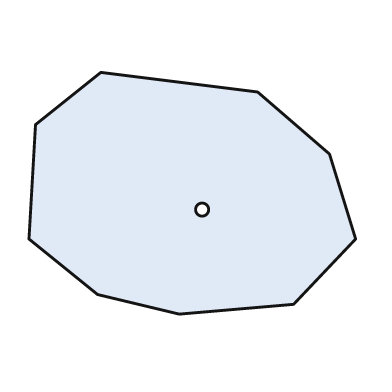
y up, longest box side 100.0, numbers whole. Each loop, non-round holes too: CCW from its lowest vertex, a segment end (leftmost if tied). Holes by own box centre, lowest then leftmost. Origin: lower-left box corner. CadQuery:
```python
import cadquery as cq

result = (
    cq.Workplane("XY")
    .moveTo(46.0, 0.0)
    .lineTo(81.0, 3.0)
    .lineTo(100.0, 23.0)
    .lineTo(92.0, 49.0)
    .lineTo(70.0, 68.0)
    .lineTo(22.0, 74.0)
    .lineTo(2.0, 58.0)
    .lineTo(0.0, 23.0)
    .lineTo(21.0, 6.0)
    .close()
    .moveTo(53.0, 32.0)
    .circle(2.0)
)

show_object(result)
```